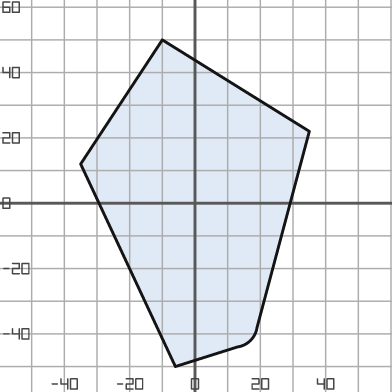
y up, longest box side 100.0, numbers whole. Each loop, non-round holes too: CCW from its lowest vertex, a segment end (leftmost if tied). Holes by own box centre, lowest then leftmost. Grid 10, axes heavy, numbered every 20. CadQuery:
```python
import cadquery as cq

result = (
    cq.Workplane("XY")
    .moveTo(-6.0, -50.0)
    .lineTo(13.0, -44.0)
    .threePointArc((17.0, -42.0), (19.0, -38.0))
    .lineTo(35.0, 22.0)
    .lineTo(-10.0, 50.0)
    .lineTo(-35.0, 12.0)
    .close()
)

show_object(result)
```